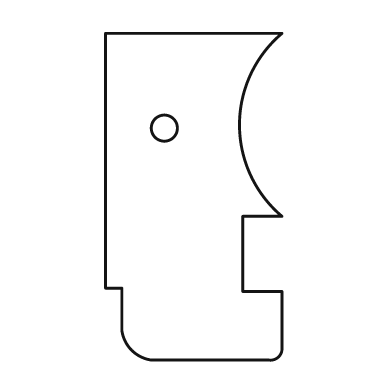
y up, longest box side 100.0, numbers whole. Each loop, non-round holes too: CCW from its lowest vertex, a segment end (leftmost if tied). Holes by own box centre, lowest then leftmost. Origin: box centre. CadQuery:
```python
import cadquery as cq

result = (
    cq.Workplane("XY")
    .moveTo(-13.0, -50.0)
    .lineTo(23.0, -50.0)
    .threePointArc((26.0, -49.0), (27.0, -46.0))
    .lineTo(27.0, -29.0)
    .lineTo(15.0, -29.0)
    .lineTo(15.0, -6.0)
    .lineTo(27.0, -6.0)
    .threePointArc((14.0, 22.0), (27.0, 50.0))
    .lineTo(-27.0, 50.0)
    .lineTo(-27.0, -28.0)
    .lineTo(-22.0, -28.0)
    .lineTo(-22.0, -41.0)
    .threePointArc((-19.0, -47.0), (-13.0, -50.0))
    .close()
    .moveTo(-9.0, 21.0)
    .circle(4.0)
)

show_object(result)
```